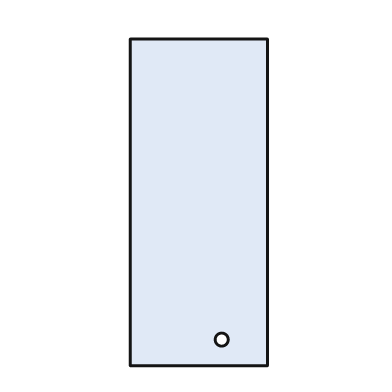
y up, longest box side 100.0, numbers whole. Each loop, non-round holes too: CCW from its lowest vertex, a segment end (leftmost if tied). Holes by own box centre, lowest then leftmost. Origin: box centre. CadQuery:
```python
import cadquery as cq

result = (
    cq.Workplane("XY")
    .moveTo(-21.0, -50.0)
    .lineTo(21.0, -50.0)
    .lineTo(21.0, 50.0)
    .lineTo(-21.0, 50.0)
    .close()
    .moveTo(7.0, -42.0)
    .circle(2.0)
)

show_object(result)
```